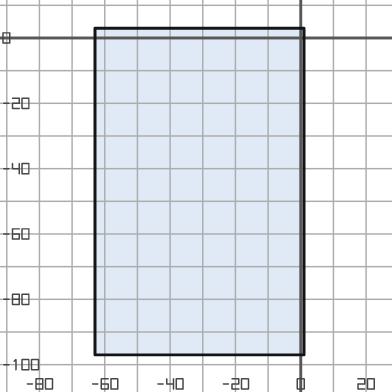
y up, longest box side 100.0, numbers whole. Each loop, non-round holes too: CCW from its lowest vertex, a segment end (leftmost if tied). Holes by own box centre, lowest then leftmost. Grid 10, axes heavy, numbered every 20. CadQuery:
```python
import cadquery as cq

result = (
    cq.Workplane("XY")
    .moveTo(-63.0, -97.0)
    .lineTo(1.0, -97.0)
    .lineTo(1.0, 3.0)
    .lineTo(-63.0, 3.0)
    .close()
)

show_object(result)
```